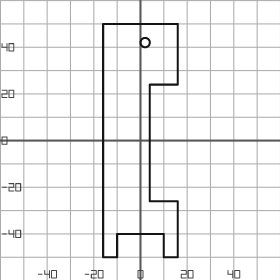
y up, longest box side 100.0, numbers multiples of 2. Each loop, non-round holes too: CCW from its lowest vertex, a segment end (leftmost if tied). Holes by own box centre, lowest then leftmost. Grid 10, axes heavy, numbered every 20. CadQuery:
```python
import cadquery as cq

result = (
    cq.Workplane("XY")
    .moveTo(-16.0, -50.0)
    .lineTo(-10.0, -50.0)
    .lineTo(-10.0, -40.0)
    .lineTo(10.0, -40.0)
    .lineTo(10.0, -50.0)
    .lineTo(16.0, -50.0)
    .lineTo(16.0, -26.0)
    .lineTo(4.0, -26.0)
    .lineTo(4.0, 24.0)
    .lineTo(16.0, 24.0)
    .lineTo(16.0, 50.0)
    .lineTo(-16.0, 50.0)
    .close()
    .moveTo(2.0, 42.0)
    .circle(2.0)
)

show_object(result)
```